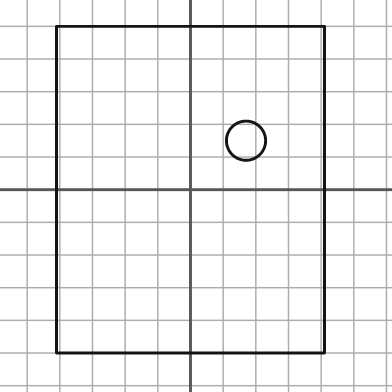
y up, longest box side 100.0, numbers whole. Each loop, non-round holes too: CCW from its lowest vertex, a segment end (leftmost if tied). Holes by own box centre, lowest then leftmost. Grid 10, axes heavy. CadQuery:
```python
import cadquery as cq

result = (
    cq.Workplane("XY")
    .moveTo(-41.0, -50.0)
    .lineTo(41.0, -50.0)
    .lineTo(41.0, 50.0)
    .lineTo(-41.0, 50.0)
    .close()
    .moveTo(17.0, 15.0)
    .circle(6.0)
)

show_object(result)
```